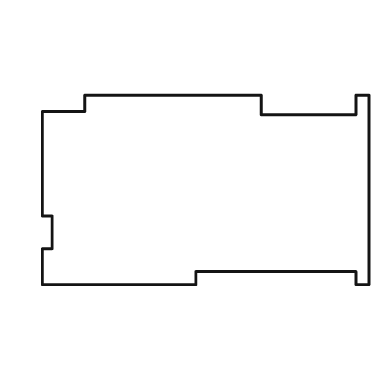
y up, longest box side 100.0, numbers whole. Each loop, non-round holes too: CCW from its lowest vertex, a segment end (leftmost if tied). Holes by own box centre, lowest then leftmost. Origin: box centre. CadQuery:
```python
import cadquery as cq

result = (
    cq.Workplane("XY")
    .moveTo(-50.0, -29.0)
    .lineTo(-3.0, -29.0)
    .lineTo(-3.0, -25.0)
    .lineTo(46.0, -25.0)
    .lineTo(46.0, -29.0)
    .lineTo(50.0, -29.0)
    .lineTo(50.0, 29.0)
    .lineTo(46.0, 29.0)
    .lineTo(46.0, 23.0)
    .lineTo(17.0, 23.0)
    .lineTo(17.0, 29.0)
    .lineTo(-37.0, 29.0)
    .lineTo(-37.0, 24.0)
    .lineTo(-50.0, 24.0)
    .lineTo(-50.0, -8.0)
    .lineTo(-47.0, -8.0)
    .lineTo(-47.0, -18.0)
    .lineTo(-50.0, -18.0)
    .close()
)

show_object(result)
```